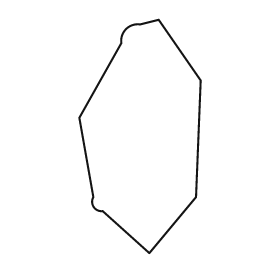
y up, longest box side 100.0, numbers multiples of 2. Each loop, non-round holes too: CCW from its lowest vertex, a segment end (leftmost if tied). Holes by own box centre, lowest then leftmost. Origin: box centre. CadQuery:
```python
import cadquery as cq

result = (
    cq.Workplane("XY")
    .moveTo(4.0, -50.0)
    .lineTo(24.0, -26.0)
    .lineTo(26.0, 24.0)
    .lineTo(8.0, 50.0)
    .lineTo(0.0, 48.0)
    .threePointArc((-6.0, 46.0), (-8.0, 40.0))
    .lineTo(-26.0, 8.0)
    .lineTo(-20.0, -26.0)
    .threePointArc((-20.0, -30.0), (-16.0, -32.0))
    .close()
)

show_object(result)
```